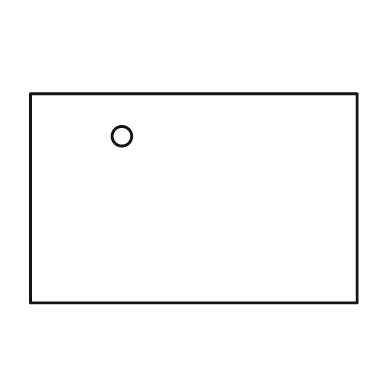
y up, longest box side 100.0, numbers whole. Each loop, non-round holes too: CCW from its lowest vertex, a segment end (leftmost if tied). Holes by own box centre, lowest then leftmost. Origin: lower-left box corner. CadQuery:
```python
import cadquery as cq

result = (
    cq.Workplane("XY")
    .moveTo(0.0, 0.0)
    .lineTo(100.0, 0.0)
    .lineTo(100.0, 64.0)
    .lineTo(0.0, 64.0)
    .close()
    .moveTo(28.0, 51.0)
    .circle(3.0)
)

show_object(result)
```